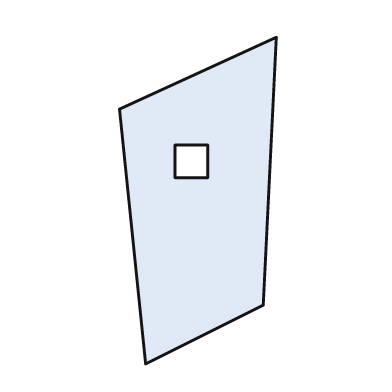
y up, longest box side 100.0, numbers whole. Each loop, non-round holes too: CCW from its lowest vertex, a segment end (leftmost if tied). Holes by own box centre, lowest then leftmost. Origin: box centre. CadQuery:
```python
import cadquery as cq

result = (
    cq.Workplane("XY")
    .moveTo(-16.0, -50.0)
    .lineTo(20.0, -32.0)
    .lineTo(24.0, 50.0)
    .lineTo(-24.0, 28.0)
    .close()
    .moveTo(-7.0, 7.0)
    .lineTo(3.0, 7.0)
    .lineTo(3.0, 17.0)
    .lineTo(-7.0, 17.0)
    .close()
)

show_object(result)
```